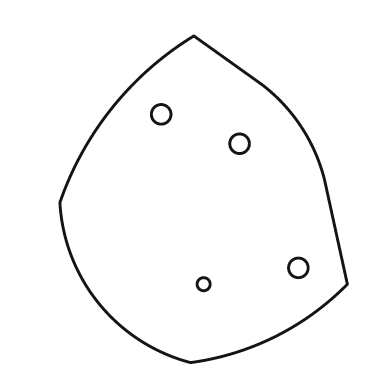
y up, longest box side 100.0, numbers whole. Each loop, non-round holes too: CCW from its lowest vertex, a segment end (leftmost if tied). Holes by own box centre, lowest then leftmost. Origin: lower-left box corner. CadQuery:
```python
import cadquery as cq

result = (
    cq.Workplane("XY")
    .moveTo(40.0, 0.0)
    .threePointArc((66.0, 8.0), (88.0, 24.0))
    .lineTo(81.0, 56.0)
    .threePointArc((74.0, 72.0), (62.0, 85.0))
    .lineTo(41.0, 100.0)
    .threePointArc((16.0, 78.0), (0.0, 49.0))
    .threePointArc((12.0, 18.0), (40.0, 0.0))
    .close()
    .moveTo(44.0, 24.0)
    .circle(2.0)
    .moveTo(73.0, 29.0)
    .circle(3.0)
    .moveTo(55.0, 67.0)
    .circle(3.0)
    .moveTo(31.0, 76.0)
    .circle(3.0)
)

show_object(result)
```